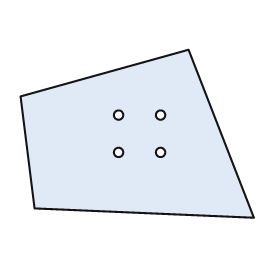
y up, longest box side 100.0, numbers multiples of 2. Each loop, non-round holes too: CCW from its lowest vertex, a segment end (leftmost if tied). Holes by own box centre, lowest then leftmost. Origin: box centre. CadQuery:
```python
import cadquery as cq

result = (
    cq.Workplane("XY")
    .moveTo(50.0, -36.0)
    .lineTo(22.0, 36.0)
    .lineTo(-50.0, 16.0)
    .lineTo(-44.0, -32.0)
    .close()
    .moveTo(-8.0, -8.0)
    .circle(2.0)
    .moveTo(10.0, -8.0)
    .circle(2.0)
    .moveTo(-8.0, 8.0)
    .circle(2.0)
    .moveTo(10.0, 8.0)
    .circle(2.0)
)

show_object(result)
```